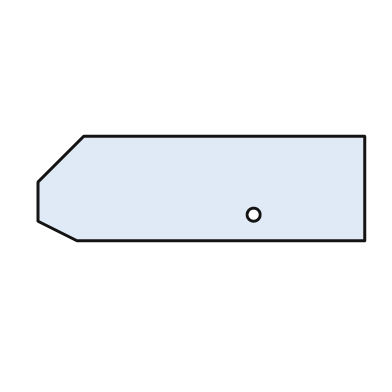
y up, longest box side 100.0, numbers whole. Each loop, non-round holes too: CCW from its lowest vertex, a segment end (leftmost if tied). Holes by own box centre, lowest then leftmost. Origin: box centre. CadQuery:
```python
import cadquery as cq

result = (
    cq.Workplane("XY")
    .moveTo(-38.0, -16.0)
    .lineTo(50.0, -16.0)
    .lineTo(50.0, 16.0)
    .lineTo(-36.0, 16.0)
    .lineTo(-50.0, 2.0)
    .lineTo(-50.0, -10.0)
    .close()
    .moveTo(16.0, -8.0)
    .circle(2.0)
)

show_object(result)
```